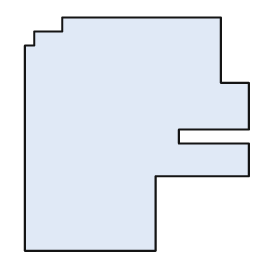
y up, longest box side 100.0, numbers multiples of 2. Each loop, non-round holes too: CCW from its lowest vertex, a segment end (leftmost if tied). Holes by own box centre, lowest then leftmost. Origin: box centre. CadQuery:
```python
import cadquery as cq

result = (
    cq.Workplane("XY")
    .moveTo(-48.0, -50.0)
    .lineTo(8.0, -50.0)
    .lineTo(8.0, -18.0)
    .lineTo(48.0, -18.0)
    .lineTo(48.0, -4.0)
    .lineTo(18.0, -4.0)
    .lineTo(18.0, 2.0)
    .lineTo(48.0, 2.0)
    .lineTo(48.0, 22.0)
    .lineTo(36.0, 22.0)
    .lineTo(36.0, 50.0)
    .lineTo(-32.0, 50.0)
    .lineTo(-32.0, 44.0)
    .lineTo(-44.0, 44.0)
    .lineTo(-44.0, 38.0)
    .lineTo(-48.0, 38.0)
    .close()
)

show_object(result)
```